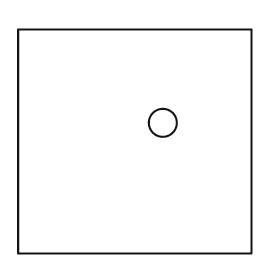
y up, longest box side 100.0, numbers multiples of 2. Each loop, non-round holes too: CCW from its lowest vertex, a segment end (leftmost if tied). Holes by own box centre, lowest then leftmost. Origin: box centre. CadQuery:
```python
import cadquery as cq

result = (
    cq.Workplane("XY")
    .moveTo(-50.0, -48.0)
    .lineTo(50.0, -48.0)
    .lineTo(50.0, 48.0)
    .lineTo(-50.0, 48.0)
    .close()
    .moveTo(12.0, 8.0)
    .circle(6.0)
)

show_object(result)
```